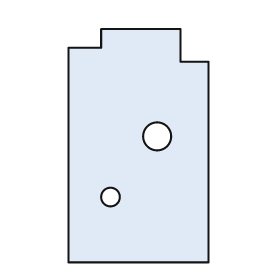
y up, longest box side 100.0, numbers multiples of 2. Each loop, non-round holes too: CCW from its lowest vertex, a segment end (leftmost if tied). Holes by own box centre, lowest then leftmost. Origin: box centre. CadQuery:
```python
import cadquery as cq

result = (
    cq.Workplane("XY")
    .moveTo(-30.0, -50.0)
    .lineTo(30.0, -50.0)
    .lineTo(30.0, 36.0)
    .lineTo(18.0, 36.0)
    .lineTo(18.0, 50.0)
    .lineTo(-16.0, 50.0)
    .lineTo(-16.0, 42.0)
    .lineTo(-30.0, 42.0)
    .close()
    .moveTo(-12.0, -22.0)
    .circle(4.0)
    .moveTo(8.0, 4.0)
    .circle(6.0)
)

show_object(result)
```